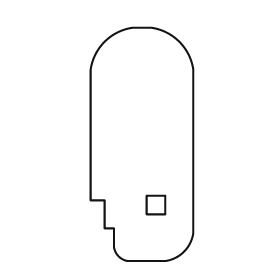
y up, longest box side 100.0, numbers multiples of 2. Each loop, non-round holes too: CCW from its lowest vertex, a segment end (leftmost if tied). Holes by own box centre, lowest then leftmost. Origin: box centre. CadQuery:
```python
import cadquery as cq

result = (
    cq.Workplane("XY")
    .moveTo(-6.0, -50.0)
    .lineTo(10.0, -50.0)
    .threePointArc((18.0, -46.0), (22.0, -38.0))
    .lineTo(22.0, 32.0)
    .threePointArc((16.0, 44.0), (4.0, 50.0))
    .lineTo(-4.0, 50.0)
    .threePointArc((-16.0, 44.0), (-22.0, 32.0))
    .lineTo(-22.0, -24.0)
    .lineTo(-16.0, -24.0)
    .lineTo(-16.0, -36.0)
    .lineTo(-12.0, -36.0)
    .lineTo(-12.0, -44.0)
    .threePointArc((-10.0, -48.0), (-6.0, -50.0))
    .close()
    .moveTo(2.0, -30.0)
    .lineTo(10.0, -30.0)
    .lineTo(10.0, -22.0)
    .lineTo(2.0, -22.0)
    .close()
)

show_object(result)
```